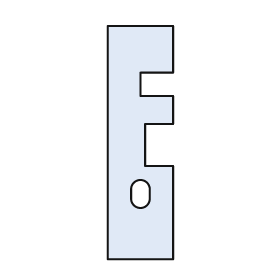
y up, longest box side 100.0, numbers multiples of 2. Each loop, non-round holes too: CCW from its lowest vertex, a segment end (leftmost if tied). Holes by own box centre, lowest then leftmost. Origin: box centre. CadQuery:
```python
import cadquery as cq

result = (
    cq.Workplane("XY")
    .moveTo(-14.0, -50.0)
    .lineTo(14.0, -50.0)
    .lineTo(14.0, -10.0)
    .lineTo(2.0, -10.0)
    .lineTo(2.0, 8.0)
    .lineTo(14.0, 8.0)
    .lineTo(14.0, 20.0)
    .lineTo(0.0, 20.0)
    .lineTo(0.0, 30.0)
    .lineTo(14.0, 30.0)
    .lineTo(14.0, 50.0)
    .lineTo(-14.0, 50.0)
    .close()
    .moveTo(-4.0, -24.0)
    .threePointArc((0.0, -28.0), (4.0, -24.0))
    .lineTo(4.0, -20.0)
    .threePointArc((0.0, -16.0), (-4.0, -20.0))
    .close()
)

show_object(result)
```